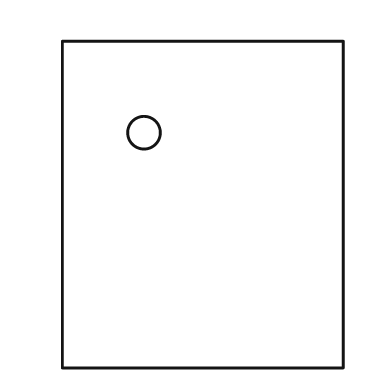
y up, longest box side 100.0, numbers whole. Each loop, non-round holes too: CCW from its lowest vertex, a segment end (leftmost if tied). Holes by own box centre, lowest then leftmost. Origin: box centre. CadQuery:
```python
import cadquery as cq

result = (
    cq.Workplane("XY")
    .moveTo(-43.0, -50.0)
    .lineTo(43.0, -50.0)
    .lineTo(43.0, 50.0)
    .lineTo(-43.0, 50.0)
    .close()
    .moveTo(-18.0, 22.0)
    .circle(5.0)
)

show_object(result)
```